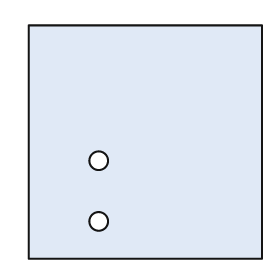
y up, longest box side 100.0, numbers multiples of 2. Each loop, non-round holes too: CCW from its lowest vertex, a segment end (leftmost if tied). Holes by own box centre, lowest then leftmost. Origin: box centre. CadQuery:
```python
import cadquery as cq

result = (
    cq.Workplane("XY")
    .moveTo(-50.0, -50.0)
    .lineTo(50.0, -50.0)
    .lineTo(50.0, 50.0)
    .lineTo(-50.0, 50.0)
    .close()
    .moveTo(-20.0, -34.0)
    .circle(4.0)
    .moveTo(-20.0, -8.0)
    .circle(4.0)
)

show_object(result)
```